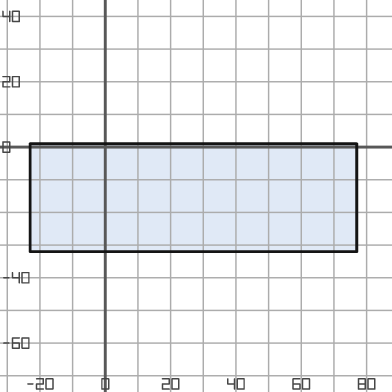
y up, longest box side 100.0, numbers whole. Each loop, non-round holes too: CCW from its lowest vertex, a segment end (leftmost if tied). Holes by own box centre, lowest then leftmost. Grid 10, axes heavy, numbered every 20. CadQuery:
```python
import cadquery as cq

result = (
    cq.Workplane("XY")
    .moveTo(-23.0, -32.0)
    .lineTo(77.0, -32.0)
    .lineTo(77.0, 1.0)
    .lineTo(-23.0, 1.0)
    .close()
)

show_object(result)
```